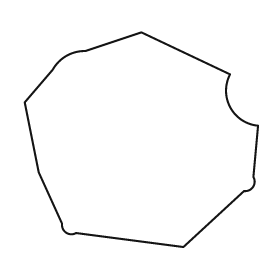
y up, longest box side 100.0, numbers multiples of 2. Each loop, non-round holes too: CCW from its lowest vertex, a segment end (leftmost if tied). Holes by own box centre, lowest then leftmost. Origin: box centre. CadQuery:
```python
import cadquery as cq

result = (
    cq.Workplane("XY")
    .moveTo(18.0, -46.0)
    .lineTo(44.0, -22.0)
    .threePointArc((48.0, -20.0), (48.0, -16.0))
    .lineTo(50.0, 6.0)
    .threePointArc((38.0, 14.0), (38.0, 28.0))
    .lineTo(0.0, 46.0)
    .lineTo(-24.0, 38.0)
    .threePointArc((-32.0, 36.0), (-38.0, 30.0))
    .lineTo(-50.0, 16.0)
    .lineTo(-44.0, -14.0)
    .lineTo(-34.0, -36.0)
    .threePointArc((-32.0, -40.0), (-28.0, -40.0))
    .close()
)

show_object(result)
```